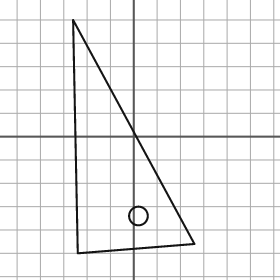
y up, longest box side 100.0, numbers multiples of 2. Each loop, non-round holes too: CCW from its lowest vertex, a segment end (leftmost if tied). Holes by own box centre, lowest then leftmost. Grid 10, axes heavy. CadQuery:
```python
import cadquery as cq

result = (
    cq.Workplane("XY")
    .moveTo(-24.0, -50.0)
    .lineTo(26.0, -46.0)
    .lineTo(-26.0, 50.0)
    .close()
    .moveTo(2.0, -34.0)
    .circle(4.0)
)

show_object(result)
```